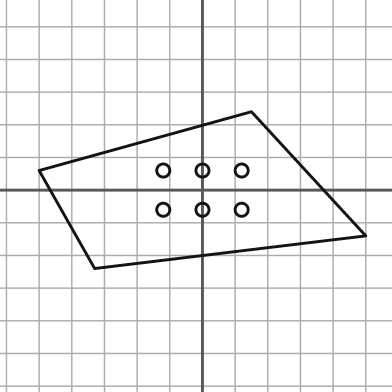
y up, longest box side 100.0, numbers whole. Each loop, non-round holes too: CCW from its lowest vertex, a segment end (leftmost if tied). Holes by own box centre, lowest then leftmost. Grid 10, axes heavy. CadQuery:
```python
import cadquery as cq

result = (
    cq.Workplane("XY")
    .moveTo(-33.0, -24.0)
    .lineTo(50.0, -14.0)
    .lineTo(15.0, 24.0)
    .lineTo(-50.0, 6.0)
    .close()
    .moveTo(-12.0, -6.0)
    .circle(2.0)
    .moveTo(0.0, -6.0)
    .circle(2.0)
    .moveTo(12.0, -6.0)
    .circle(2.0)
    .moveTo(-12.0, 6.0)
    .circle(2.0)
    .moveTo(0.0, 6.0)
    .circle(2.0)
    .moveTo(12.0, 6.0)
    .circle(2.0)
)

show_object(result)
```